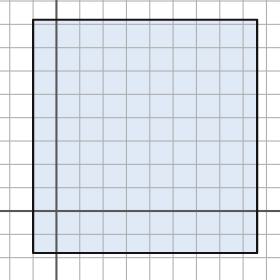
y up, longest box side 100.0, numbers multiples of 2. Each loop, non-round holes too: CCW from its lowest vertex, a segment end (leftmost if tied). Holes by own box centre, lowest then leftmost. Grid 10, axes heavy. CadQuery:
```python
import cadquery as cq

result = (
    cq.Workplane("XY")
    .moveTo(-10.0, -18.0)
    .lineTo(86.0, -18.0)
    .lineTo(86.0, 82.0)
    .lineTo(-10.0, 82.0)
    .close()
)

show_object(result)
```